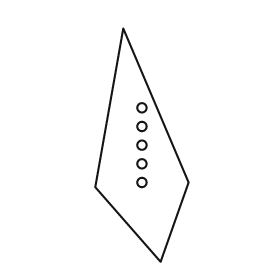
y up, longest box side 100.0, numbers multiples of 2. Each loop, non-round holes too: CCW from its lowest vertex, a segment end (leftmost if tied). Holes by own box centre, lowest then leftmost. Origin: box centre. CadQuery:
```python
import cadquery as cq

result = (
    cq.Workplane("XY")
    .moveTo(8.0, -50.0)
    .lineTo(20.0, -16.0)
    .lineTo(-8.0, 50.0)
    .lineTo(-20.0, -18.0)
    .close()
    .moveTo(0.0, -16.0)
    .circle(2.0)
    .moveTo(0.0, -8.0)
    .circle(2.0)
    .moveTo(0.0, 0.0)
    .circle(2.0)
    .moveTo(0.0, 8.0)
    .circle(2.0)
    .moveTo(0.0, 16.0)
    .circle(2.0)
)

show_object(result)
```